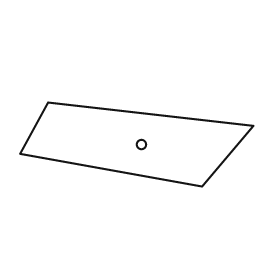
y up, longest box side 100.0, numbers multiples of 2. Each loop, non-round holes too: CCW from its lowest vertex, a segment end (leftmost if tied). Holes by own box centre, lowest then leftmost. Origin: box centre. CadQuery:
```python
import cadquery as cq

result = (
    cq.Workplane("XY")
    .moveTo(28.0, -18.0)
    .lineTo(50.0, 8.0)
    .lineTo(-38.0, 18.0)
    .lineTo(-50.0, -4.0)
    .close()
    .moveTo(2.0, 0.0)
    .circle(2.0)
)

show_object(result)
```